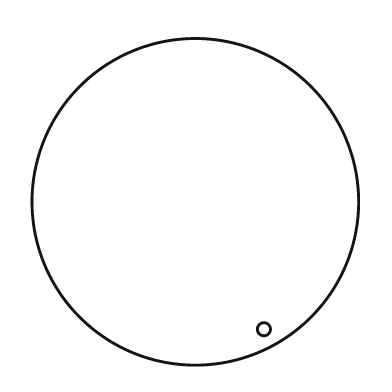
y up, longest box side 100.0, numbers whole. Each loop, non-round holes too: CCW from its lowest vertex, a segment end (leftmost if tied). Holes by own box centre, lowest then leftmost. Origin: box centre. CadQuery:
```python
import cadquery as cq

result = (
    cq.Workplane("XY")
    .moveTo(0.0, 0.0)
    .circle(50.0)
    .moveTo(21.0, -39.0)
    .circle(2.0)
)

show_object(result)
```